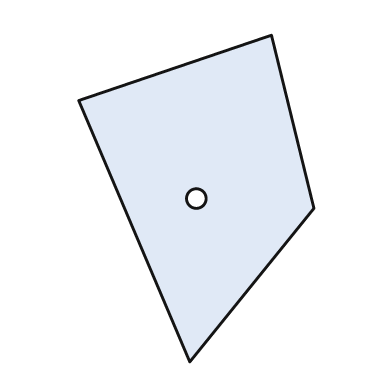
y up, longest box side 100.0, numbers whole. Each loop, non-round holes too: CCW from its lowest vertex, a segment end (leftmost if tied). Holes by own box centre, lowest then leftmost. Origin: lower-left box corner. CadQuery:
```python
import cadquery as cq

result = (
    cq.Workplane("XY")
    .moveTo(34.0, 0.0)
    .lineTo(72.0, 47.0)
    .lineTo(59.0, 100.0)
    .lineTo(0.0, 80.0)
    .close()
    .moveTo(36.0, 50.0)
    .circle(3.0)
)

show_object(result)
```